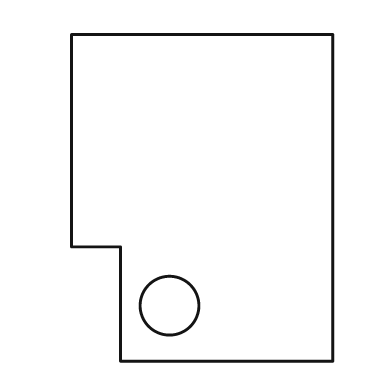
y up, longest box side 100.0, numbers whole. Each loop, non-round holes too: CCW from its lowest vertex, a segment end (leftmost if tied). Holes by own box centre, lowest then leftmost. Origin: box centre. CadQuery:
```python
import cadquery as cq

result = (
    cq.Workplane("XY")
    .moveTo(-25.0, -50.0)
    .lineTo(40.0, -50.0)
    .lineTo(40.0, 50.0)
    .lineTo(-40.0, 50.0)
    .lineTo(-40.0, -15.0)
    .lineTo(-25.0, -15.0)
    .close()
    .moveTo(-10.0, -33.0)
    .circle(9.0)
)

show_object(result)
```